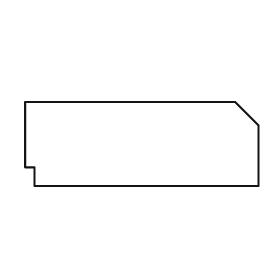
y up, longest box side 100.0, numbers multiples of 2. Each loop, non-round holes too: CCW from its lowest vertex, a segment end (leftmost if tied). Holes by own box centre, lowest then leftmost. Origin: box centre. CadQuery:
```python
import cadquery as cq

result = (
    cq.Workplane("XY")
    .moveTo(-46.0, -18.0)
    .lineTo(50.0, -18.0)
    .lineTo(50.0, 8.0)
    .lineTo(40.0, 18.0)
    .lineTo(-50.0, 18.0)
    .lineTo(-50.0, -10.0)
    .lineTo(-46.0, -10.0)
    .close()
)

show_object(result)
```